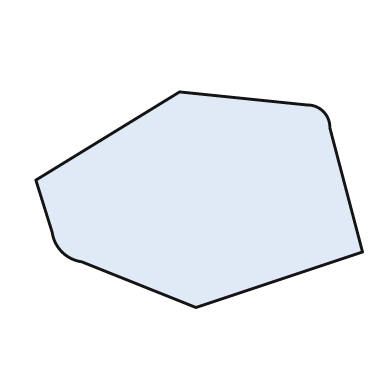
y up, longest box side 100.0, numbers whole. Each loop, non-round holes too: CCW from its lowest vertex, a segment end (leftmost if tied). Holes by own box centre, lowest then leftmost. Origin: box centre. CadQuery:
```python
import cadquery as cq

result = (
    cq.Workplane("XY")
    .moveTo(-1.0, -33.0)
    .lineTo(50.0, -16.0)
    .lineTo(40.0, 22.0)
    .threePointArc((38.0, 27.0), (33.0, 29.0))
    .lineTo(-6.0, 33.0)
    .lineTo(-50.0, 6.0)
    .lineTo(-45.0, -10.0)
    .threePointArc((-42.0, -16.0), (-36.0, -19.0))
    .close()
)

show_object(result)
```